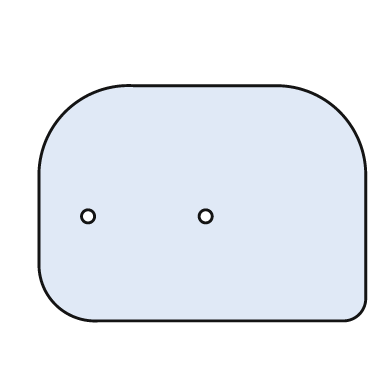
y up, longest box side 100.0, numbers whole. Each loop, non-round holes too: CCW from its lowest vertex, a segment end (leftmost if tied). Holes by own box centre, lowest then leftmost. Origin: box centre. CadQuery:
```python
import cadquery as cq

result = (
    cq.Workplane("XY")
    .moveTo(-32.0, -36.0)
    .lineTo(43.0, -36.0)
    .threePointArc((48.0, -34.0), (50.0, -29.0))
    .lineTo(50.0, 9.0)
    .threePointArc((42.0, 28.0), (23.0, 36.0))
    .lineTo(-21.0, 36.0)
    .threePointArc((-42.0, 28.0), (-50.0, 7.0))
    .lineTo(-50.0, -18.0)
    .threePointArc((-45.0, -31.0), (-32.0, -36.0))
    .close()
    .moveTo(-35.0, -4.0)
    .circle(2.0)
    .moveTo(1.0, -4.0)
    .circle(2.0)
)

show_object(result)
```